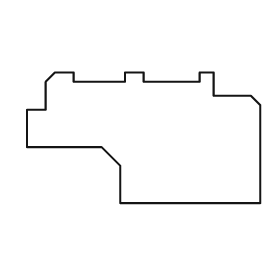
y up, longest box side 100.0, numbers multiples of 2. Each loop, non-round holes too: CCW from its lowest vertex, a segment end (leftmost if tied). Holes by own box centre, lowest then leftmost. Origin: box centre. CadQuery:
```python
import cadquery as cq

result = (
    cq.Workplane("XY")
    .moveTo(-10.0, -28.0)
    .lineTo(50.0, -28.0)
    .lineTo(50.0, 14.0)
    .lineTo(46.0, 18.0)
    .lineTo(30.0, 18.0)
    .lineTo(30.0, 28.0)
    .lineTo(24.0, 28.0)
    .lineTo(24.0, 24.0)
    .lineTo(0.0, 24.0)
    .lineTo(0.0, 28.0)
    .lineTo(-8.0, 28.0)
    .lineTo(-8.0, 24.0)
    .lineTo(-30.0, 24.0)
    .lineTo(-30.0, 28.0)
    .lineTo(-38.0, 28.0)
    .lineTo(-42.0, 24.0)
    .lineTo(-42.0, 12.0)
    .lineTo(-50.0, 12.0)
    .lineTo(-50.0, -4.0)
    .lineTo(-18.0, -4.0)
    .lineTo(-10.0, -12.0)
    .close()
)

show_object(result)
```